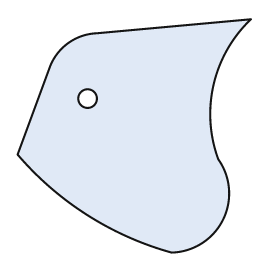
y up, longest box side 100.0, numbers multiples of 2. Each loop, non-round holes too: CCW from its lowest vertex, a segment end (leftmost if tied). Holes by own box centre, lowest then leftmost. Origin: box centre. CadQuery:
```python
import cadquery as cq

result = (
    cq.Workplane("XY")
    .moveTo(16.0, -50.0)
    .threePointArc((38.0, -36.0), (36.0, -10.0))
    .threePointArc((34.0, 22.0), (50.0, 50.0))
    .lineTo(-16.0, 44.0)
    .threePointArc((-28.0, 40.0), (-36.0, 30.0))
    .lineTo(-50.0, -8.0)
    .threePointArc((-20.0, -34.0), (16.0, -50.0))
    .close()
    .moveTo(-20.0, 16.0)
    .circle(4.0)
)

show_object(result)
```